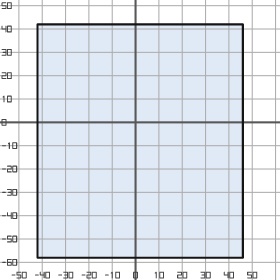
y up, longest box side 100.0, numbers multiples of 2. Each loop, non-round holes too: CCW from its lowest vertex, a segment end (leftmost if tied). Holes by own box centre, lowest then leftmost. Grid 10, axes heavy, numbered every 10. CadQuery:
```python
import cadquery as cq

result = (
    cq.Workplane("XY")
    .moveTo(-42.0, -58.0)
    .lineTo(46.0, -58.0)
    .lineTo(46.0, 42.0)
    .lineTo(-42.0, 42.0)
    .close()
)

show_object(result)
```